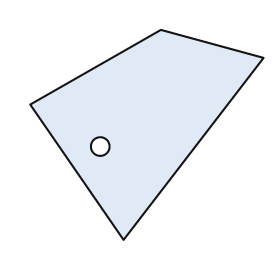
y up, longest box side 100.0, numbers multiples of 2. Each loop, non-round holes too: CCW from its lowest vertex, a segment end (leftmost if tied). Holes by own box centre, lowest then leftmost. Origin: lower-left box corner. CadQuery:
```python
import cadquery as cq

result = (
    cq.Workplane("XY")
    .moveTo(40.0, 0.0)
    .lineTo(100.0, 78.0)
    .lineTo(56.0, 90.0)
    .lineTo(0.0, 58.0)
    .close()
    .moveTo(30.0, 40.0)
    .circle(4.0)
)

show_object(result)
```